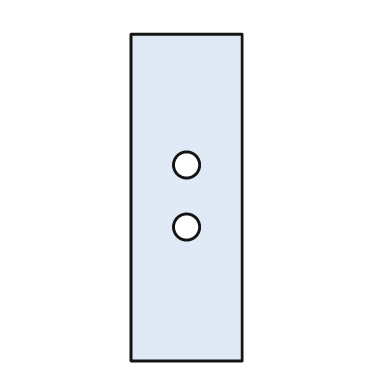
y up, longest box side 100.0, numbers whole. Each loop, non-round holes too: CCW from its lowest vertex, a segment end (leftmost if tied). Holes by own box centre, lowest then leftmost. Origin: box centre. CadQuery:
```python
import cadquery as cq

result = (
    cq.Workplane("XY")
    .moveTo(-17.0, -50.0)
    .lineTo(17.0, -50.0)
    .lineTo(17.0, 50.0)
    .lineTo(-17.0, 50.0)
    .close()
    .moveTo(0.0, -9.0)
    .circle(4.0)
    .moveTo(0.0, 10.0)
    .circle(4.0)
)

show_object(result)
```